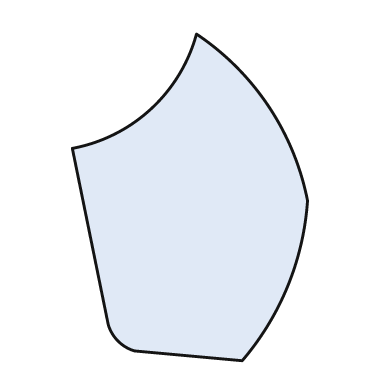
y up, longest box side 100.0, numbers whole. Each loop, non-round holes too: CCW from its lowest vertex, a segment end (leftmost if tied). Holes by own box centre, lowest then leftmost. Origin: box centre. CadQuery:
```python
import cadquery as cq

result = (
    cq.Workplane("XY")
    .moveTo(16.0, -50.0)
    .threePointArc((30.0, -27.0), (36.0, -1.0))
    .threePointArc((24.0, 28.0), (2.0, 50.0))
    .threePointArc((-12.0, 27.0), (-36.0, 15.0))
    .lineTo(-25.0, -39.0)
    .threePointArc((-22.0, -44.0), (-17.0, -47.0))
    .close()
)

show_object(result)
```